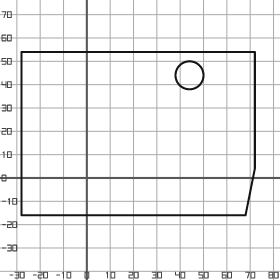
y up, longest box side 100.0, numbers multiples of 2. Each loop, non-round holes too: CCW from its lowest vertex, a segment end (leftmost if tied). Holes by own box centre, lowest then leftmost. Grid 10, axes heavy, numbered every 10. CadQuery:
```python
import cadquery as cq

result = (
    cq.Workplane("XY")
    .moveTo(-28.0, -16.0)
    .lineTo(68.0, -16.0)
    .lineTo(72.0, 4.0)
    .lineTo(72.0, 54.0)
    .lineTo(-28.0, 54.0)
    .close()
    .moveTo(44.0, 44.0)
    .circle(6.0)
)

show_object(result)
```